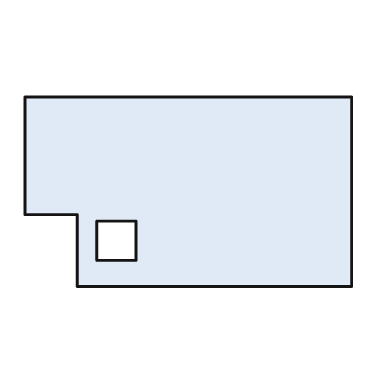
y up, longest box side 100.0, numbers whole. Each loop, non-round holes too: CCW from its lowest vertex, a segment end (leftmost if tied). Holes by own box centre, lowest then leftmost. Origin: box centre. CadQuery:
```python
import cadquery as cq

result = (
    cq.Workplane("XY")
    .moveTo(-34.0, -29.0)
    .lineTo(50.0, -29.0)
    .lineTo(50.0, 29.0)
    .lineTo(-50.0, 29.0)
    .lineTo(-50.0, -7.0)
    .lineTo(-34.0, -7.0)
    .close()
    .moveTo(-28.0, -21.0)
    .lineTo(-16.0, -21.0)
    .lineTo(-16.0, -9.0)
    .lineTo(-28.0, -9.0)
    .close()
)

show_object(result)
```